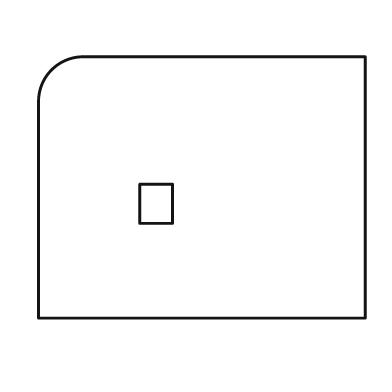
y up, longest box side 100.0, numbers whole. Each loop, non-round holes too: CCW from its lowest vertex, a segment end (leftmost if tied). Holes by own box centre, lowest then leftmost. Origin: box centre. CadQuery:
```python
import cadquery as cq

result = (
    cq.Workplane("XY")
    .moveTo(-50.0, -40.0)
    .lineTo(50.0, -40.0)
    .lineTo(50.0, 40.0)
    .lineTo(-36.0, 40.0)
    .threePointArc((-46.0, 36.0), (-50.0, 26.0))
    .close()
    .moveTo(-19.0, -11.0)
    .lineTo(-9.0, -11.0)
    .lineTo(-9.0, 1.0)
    .lineTo(-19.0, 1.0)
    .close()
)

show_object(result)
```